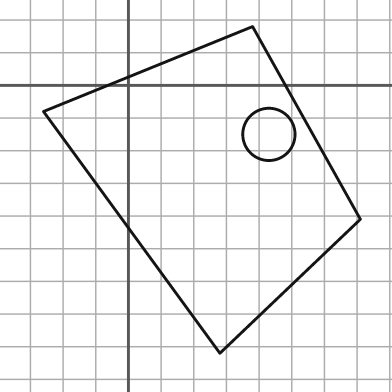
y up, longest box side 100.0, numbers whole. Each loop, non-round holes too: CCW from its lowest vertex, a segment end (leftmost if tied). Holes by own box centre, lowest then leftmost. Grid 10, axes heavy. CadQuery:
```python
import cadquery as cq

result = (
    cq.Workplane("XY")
    .moveTo(28.0, -82.0)
    .lineTo(71.0, -41.0)
    .lineTo(38.0, 18.0)
    .lineTo(-26.0, -8.0)
    .close()
    .moveTo(43.0, -15.0)
    .circle(8.0)
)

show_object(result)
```